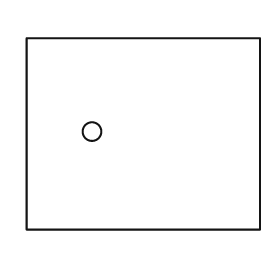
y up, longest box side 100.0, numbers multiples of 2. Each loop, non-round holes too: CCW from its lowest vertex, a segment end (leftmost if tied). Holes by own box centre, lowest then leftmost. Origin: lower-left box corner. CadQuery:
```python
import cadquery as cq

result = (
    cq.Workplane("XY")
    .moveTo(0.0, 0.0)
    .lineTo(100.0, 0.0)
    .lineTo(100.0, 82.0)
    .lineTo(0.0, 82.0)
    .close()
    .moveTo(28.0, 42.0)
    .circle(4.0)
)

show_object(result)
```